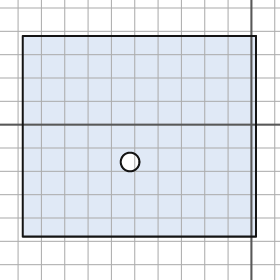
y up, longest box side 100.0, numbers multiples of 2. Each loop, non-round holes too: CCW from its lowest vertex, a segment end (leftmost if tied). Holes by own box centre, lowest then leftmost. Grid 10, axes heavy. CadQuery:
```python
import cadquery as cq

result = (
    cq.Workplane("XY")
    .moveTo(-98.0, -48.0)
    .lineTo(2.0, -48.0)
    .lineTo(2.0, 38.0)
    .lineTo(-98.0, 38.0)
    .close()
    .moveTo(-52.0, -16.0)
    .circle(4.0)
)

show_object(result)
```